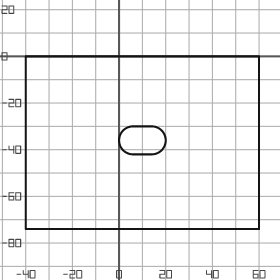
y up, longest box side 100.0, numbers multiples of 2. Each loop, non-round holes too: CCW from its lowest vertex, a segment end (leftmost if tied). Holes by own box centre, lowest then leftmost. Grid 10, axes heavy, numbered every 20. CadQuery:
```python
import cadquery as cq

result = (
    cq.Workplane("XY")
    .moveTo(-40.0, -74.0)
    .lineTo(60.0, -74.0)
    .lineTo(60.0, 0.0)
    .lineTo(-40.0, 0.0)
    .close()
    .moveTo(6.0, -42.0)
    .lineTo(14.0, -42.0)
    .threePointArc((20.0, -36.0), (14.0, -30.0))
    .lineTo(6.0, -30.0)
    .threePointArc((0.0, -36.0), (6.0, -42.0))
    .close()
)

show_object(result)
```